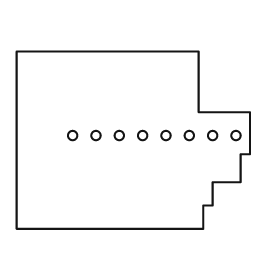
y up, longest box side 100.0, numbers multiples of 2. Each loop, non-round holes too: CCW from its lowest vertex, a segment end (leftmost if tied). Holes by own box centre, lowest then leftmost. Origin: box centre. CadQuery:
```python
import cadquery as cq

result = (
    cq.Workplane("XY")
    .moveTo(-50.0, -38.0)
    .lineTo(30.0, -38.0)
    .lineTo(30.0, -28.0)
    .lineTo(34.0, -28.0)
    .lineTo(34.0, -18.0)
    .lineTo(46.0, -18.0)
    .lineTo(46.0, -6.0)
    .lineTo(50.0, -6.0)
    .lineTo(50.0, 12.0)
    .lineTo(28.0, 12.0)
    .lineTo(28.0, 38.0)
    .lineTo(-50.0, 38.0)
    .close()
    .moveTo(-26.0, 2.0)
    .circle(2.0)
    .moveTo(-16.0, 2.0)
    .circle(2.0)
    .moveTo(-6.0, 2.0)
    .circle(2.0)
    .moveTo(4.0, 2.0)
    .circle(2.0)
    .moveTo(14.0, 2.0)
    .circle(2.0)
    .moveTo(24.0, 2.0)
    .circle(2.0)
    .moveTo(34.0, 2.0)
    .circle(2.0)
    .moveTo(44.0, 2.0)
    .circle(2.0)
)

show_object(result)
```